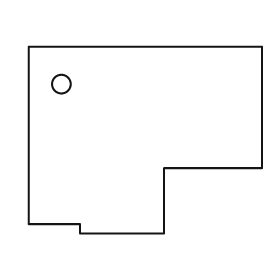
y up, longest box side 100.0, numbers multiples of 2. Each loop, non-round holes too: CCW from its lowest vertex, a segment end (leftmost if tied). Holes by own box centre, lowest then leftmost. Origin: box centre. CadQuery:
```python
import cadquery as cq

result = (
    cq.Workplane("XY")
    .moveTo(-28.0, -40.0)
    .lineTo(8.0, -40.0)
    .lineTo(8.0, -12.0)
    .lineTo(50.0, -12.0)
    .lineTo(50.0, 40.0)
    .lineTo(-50.0, 40.0)
    .lineTo(-50.0, -36.0)
    .lineTo(-28.0, -36.0)
    .close()
    .moveTo(-36.0, 24.0)
    .circle(4.0)
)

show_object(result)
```